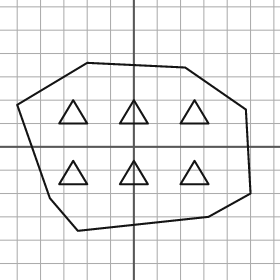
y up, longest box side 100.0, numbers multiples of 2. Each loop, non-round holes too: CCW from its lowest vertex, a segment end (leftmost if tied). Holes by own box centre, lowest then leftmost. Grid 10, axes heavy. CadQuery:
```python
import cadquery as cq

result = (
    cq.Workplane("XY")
    .moveTo(-24.0, -36.0)
    .lineTo(32.0, -30.0)
    .lineTo(50.0, -20.0)
    .lineTo(48.0, 16.0)
    .lineTo(22.0, 34.0)
    .lineTo(-20.0, 36.0)
    .lineTo(-50.0, 18.0)
    .lineTo(-36.0, -22.0)
    .close()
    .moveTo(-32.0, -16.0)
    .lineTo(-20.0, -16.0)
    .lineTo(-26.0, -6.0)
    .close()
    .moveTo(-6.0, -16.0)
    .lineTo(6.0, -16.0)
    .lineTo(0.0, -6.0)
    .close()
    .moveTo(20.0, -16.0)
    .lineTo(32.0, -16.0)
    .lineTo(26.0, -6.0)
    .close()
    .moveTo(-32.0, 10.0)
    .lineTo(-20.0, 10.0)
    .lineTo(-26.0, 20.0)
    .close()
    .moveTo(-6.0, 10.0)
    .lineTo(6.0, 10.0)
    .lineTo(0.0, 20.0)
    .close()
    .moveTo(20.0, 10.0)
    .lineTo(32.0, 10.0)
    .lineTo(26.0, 20.0)
    .close()
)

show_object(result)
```